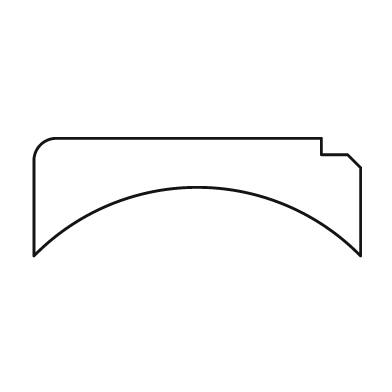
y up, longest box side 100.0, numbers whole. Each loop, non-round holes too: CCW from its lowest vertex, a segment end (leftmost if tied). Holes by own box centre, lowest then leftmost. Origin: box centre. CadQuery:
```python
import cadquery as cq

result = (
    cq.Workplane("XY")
    .moveTo(-50.0, -18.0)
    .threePointArc((0.0, 3.0), (50.0, -18.0))
    .lineTo(50.0, 9.0)
    .lineTo(46.0, 13.0)
    .lineTo(38.0, 13.0)
    .lineTo(38.0, 18.0)
    .lineTo(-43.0, 18.0)
    .threePointArc((-48.0, 16.0), (-50.0, 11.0))
    .close()
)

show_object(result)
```